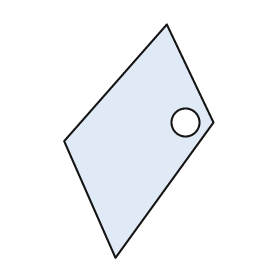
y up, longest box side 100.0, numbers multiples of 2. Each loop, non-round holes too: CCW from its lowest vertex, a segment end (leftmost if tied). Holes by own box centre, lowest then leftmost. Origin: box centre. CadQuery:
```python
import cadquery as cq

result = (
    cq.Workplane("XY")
    .moveTo(-10.0, -50.0)
    .lineTo(32.0, 8.0)
    .lineTo(12.0, 50.0)
    .lineTo(-32.0, 0.0)
    .close()
    .moveTo(20.0, 8.0)
    .circle(6.0)
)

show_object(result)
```